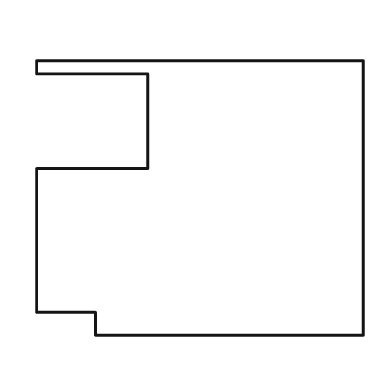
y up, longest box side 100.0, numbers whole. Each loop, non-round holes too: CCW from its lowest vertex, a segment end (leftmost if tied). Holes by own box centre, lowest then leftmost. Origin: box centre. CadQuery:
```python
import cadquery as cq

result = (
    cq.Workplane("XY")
    .moveTo(-32.0, -42.0)
    .lineTo(50.0, -42.0)
    .lineTo(50.0, 42.0)
    .lineTo(-50.0, 42.0)
    .lineTo(-50.0, 38.0)
    .lineTo(-16.0, 38.0)
    .lineTo(-16.0, 9.0)
    .lineTo(-50.0, 9.0)
    .lineTo(-50.0, -35.0)
    .lineTo(-32.0, -35.0)
    .close()
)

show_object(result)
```